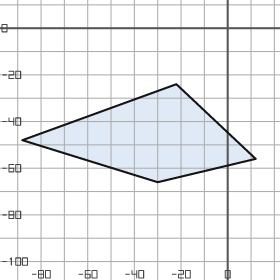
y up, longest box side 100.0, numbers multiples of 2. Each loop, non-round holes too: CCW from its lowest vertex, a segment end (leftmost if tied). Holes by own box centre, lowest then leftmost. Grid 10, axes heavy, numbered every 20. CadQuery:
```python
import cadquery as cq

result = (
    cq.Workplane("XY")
    .moveTo(-30.0, -66.0)
    .lineTo(12.0, -56.0)
    .lineTo(-22.0, -24.0)
    .lineTo(-88.0, -48.0)
    .close()
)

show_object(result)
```